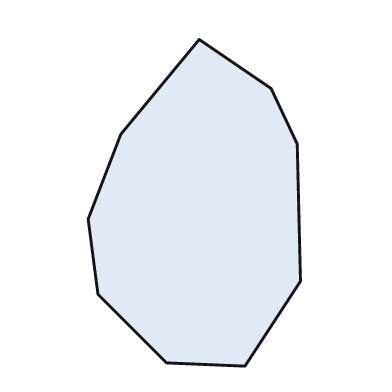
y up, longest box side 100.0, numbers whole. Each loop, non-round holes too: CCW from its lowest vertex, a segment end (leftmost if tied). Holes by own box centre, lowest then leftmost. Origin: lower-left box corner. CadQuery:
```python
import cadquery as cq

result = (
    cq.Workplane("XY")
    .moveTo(48.0, 0.0)
    .lineTo(65.0, 26.0)
    .lineTo(64.0, 68.0)
    .lineTo(56.0, 85.0)
    .lineTo(34.0, 100.0)
    .lineTo(10.0, 71.0)
    .lineTo(0.0, 45.0)
    .lineTo(3.0, 22.0)
    .lineTo(24.0, 1.0)
    .close()
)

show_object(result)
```